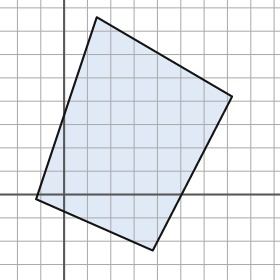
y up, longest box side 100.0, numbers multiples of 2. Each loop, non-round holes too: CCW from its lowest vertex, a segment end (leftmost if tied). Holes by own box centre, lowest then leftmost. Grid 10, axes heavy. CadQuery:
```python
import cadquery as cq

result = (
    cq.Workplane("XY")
    .moveTo(38.0, -24.0)
    .lineTo(72.0, 42.0)
    .lineTo(14.0, 76.0)
    .lineTo(-12.0, -2.0)
    .close()
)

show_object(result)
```